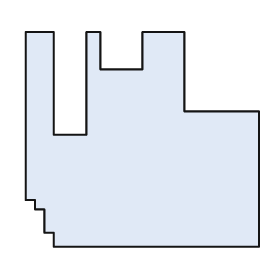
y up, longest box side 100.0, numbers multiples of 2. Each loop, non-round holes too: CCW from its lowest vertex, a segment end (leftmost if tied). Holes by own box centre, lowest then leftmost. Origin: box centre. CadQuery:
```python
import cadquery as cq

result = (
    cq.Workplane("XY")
    .moveTo(-38.0, -46.0)
    .lineTo(50.0, -46.0)
    .lineTo(50.0, 12.0)
    .lineTo(18.0, 12.0)
    .lineTo(18.0, 46.0)
    .lineTo(0.0, 46.0)
    .lineTo(0.0, 30.0)
    .lineTo(-18.0, 30.0)
    .lineTo(-18.0, 46.0)
    .lineTo(-24.0, 46.0)
    .lineTo(-24.0, 2.0)
    .lineTo(-38.0, 2.0)
    .lineTo(-38.0, 46.0)
    .lineTo(-50.0, 46.0)
    .lineTo(-50.0, -26.0)
    .lineTo(-46.0, -26.0)
    .lineTo(-46.0, -30.0)
    .lineTo(-42.0, -30.0)
    .lineTo(-42.0, -40.0)
    .lineTo(-38.0, -40.0)
    .close()
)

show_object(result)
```